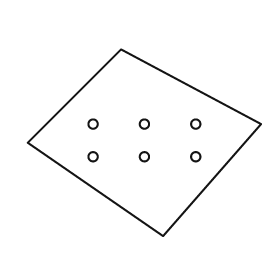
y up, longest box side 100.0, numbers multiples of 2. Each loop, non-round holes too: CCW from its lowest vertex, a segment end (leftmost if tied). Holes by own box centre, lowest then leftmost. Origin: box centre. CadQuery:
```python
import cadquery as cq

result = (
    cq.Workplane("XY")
    .moveTo(8.0, -40.0)
    .lineTo(50.0, 8.0)
    .lineTo(-10.0, 40.0)
    .lineTo(-50.0, 0.0)
    .close()
    .moveTo(-22.0, -6.0)
    .circle(2.0)
    .moveTo(0.0, -6.0)
    .circle(2.0)
    .moveTo(22.0, -6.0)
    .circle(2.0)
    .moveTo(-22.0, 8.0)
    .circle(2.0)
    .moveTo(0.0, 8.0)
    .circle(2.0)
    .moveTo(22.0, 8.0)
    .circle(2.0)
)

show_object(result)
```